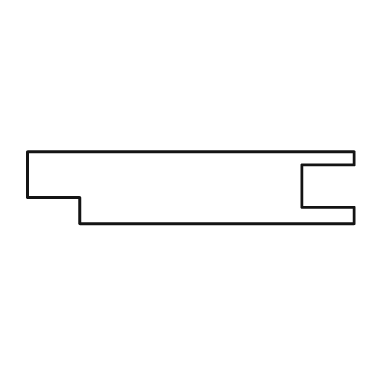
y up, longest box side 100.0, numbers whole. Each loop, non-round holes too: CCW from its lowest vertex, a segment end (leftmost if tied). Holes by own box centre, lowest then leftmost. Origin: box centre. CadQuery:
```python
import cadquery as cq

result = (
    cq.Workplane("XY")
    .moveTo(-34.0, -11.0)
    .lineTo(50.0, -11.0)
    .lineTo(50.0, -6.0)
    .lineTo(34.0, -6.0)
    .lineTo(34.0, 7.0)
    .lineTo(50.0, 7.0)
    .lineTo(50.0, 11.0)
    .lineTo(-50.0, 11.0)
    .lineTo(-50.0, -3.0)
    .lineTo(-34.0, -3.0)
    .close()
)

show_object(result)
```